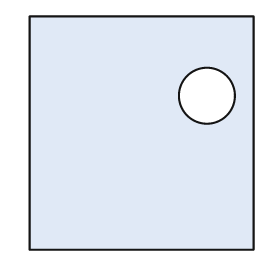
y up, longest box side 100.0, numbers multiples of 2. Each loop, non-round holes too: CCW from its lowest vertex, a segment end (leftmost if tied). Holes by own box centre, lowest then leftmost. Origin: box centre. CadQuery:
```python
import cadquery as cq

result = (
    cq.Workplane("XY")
    .moveTo(-48.0, -50.0)
    .lineTo(48.0, -50.0)
    .lineTo(48.0, 50.0)
    .lineTo(-48.0, 50.0)
    .close()
    .moveTo(28.0, 16.0)
    .circle(12.0)
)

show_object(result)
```